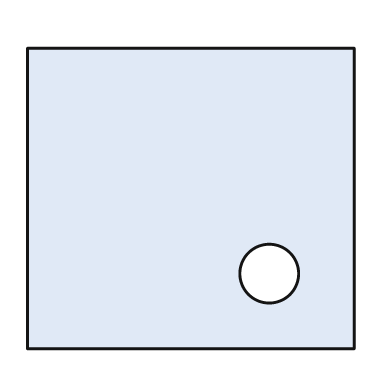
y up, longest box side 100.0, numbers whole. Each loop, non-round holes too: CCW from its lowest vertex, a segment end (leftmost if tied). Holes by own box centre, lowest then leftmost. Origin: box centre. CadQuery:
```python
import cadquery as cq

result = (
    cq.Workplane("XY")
    .moveTo(-50.0, -46.0)
    .lineTo(50.0, -46.0)
    .lineTo(50.0, 46.0)
    .lineTo(-50.0, 46.0)
    .close()
    .moveTo(24.0, -23.0)
    .circle(9.0)
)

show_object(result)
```